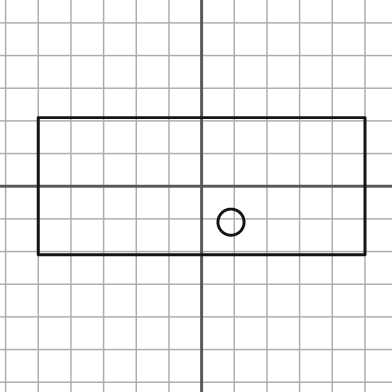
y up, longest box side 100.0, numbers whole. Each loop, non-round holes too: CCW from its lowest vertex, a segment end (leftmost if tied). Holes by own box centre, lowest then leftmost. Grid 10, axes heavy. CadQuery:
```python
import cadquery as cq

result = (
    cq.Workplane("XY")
    .moveTo(-50.0, -21.0)
    .lineTo(50.0, -21.0)
    .lineTo(50.0, 21.0)
    .lineTo(-50.0, 21.0)
    .close()
    .moveTo(9.0, -11.0)
    .circle(4.0)
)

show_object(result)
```